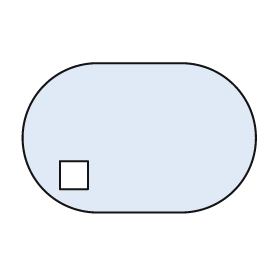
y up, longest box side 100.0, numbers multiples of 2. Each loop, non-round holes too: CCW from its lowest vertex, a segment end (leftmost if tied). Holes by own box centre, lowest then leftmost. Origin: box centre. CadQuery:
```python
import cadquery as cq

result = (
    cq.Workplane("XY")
    .moveTo(-18.0, -32.0)
    .lineTo(18.0, -32.0)
    .threePointArc((50.0, 0.0), (18.0, 32.0))
    .lineTo(-18.0, 32.0)
    .threePointArc((-50.0, 0.0), (-18.0, -32.0))
    .close()
    .moveTo(-34.0, -22.0)
    .lineTo(-22.0, -22.0)
    .lineTo(-22.0, -10.0)
    .lineTo(-34.0, -10.0)
    .close()
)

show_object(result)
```